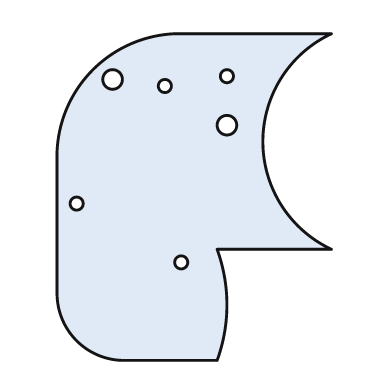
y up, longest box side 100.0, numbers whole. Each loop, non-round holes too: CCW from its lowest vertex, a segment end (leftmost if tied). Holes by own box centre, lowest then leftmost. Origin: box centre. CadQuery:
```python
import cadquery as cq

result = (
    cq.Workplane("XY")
    .moveTo(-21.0, -50.0)
    .lineTo(7.0, -50.0)
    .threePointArc((10.0, -33.0), (7.0, -16.0))
    .lineTo(42.0, -16.0)
    .threePointArc((21.0, 17.0), (42.0, 50.0))
    .lineTo(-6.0, 50.0)
    .threePointArc((-31.0, 39.0), (-42.0, 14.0))
    .lineTo(-42.0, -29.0)
    .threePointArc((-36.0, -44.0), (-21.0, -50.0))
    .close()
    .moveTo(-4.0, -20.0)
    .circle(2.0)
    .moveTo(-36.0, -2.0)
    .circle(2.0)
    .moveTo(10.0, 22.0)
    .circle(3.0)
    .moveTo(-9.0, 34.0)
    .circle(2.0)
    .moveTo(-25.0, 36.0)
    .circle(3.0)
    .moveTo(10.0, 37.0)
    .circle(2.0)
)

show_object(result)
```